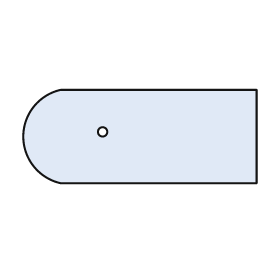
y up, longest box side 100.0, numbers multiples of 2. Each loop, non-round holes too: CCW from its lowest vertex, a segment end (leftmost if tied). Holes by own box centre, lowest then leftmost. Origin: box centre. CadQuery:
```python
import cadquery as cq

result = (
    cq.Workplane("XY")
    .moveTo(-34.0, -20.0)
    .lineTo(50.0, -20.0)
    .lineTo(50.0, 20.0)
    .lineTo(-34.0, 20.0)
    .threePointArc((-50.0, 0.0), (-34.0, -20.0))
    .close()
    .moveTo(-16.0, 2.0)
    .circle(2.0)
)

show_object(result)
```